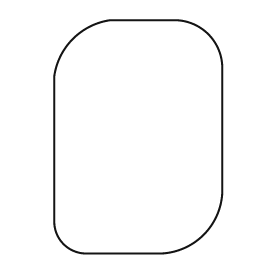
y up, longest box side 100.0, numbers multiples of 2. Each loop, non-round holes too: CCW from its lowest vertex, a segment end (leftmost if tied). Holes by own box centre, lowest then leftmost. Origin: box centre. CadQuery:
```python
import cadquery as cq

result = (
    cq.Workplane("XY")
    .moveTo(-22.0, -50.0)
    .lineTo(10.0, -50.0)
    .threePointArc((28.0, -42.0), (36.0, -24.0))
    .lineTo(36.0, 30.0)
    .threePointArc((30.0, 44.0), (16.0, 50.0))
    .lineTo(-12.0, 50.0)
    .threePointArc((-28.0, 42.0), (-36.0, 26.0))
    .lineTo(-36.0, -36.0)
    .threePointArc((-32.0, -46.0), (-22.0, -50.0))
    .close()
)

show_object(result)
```